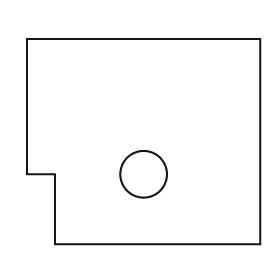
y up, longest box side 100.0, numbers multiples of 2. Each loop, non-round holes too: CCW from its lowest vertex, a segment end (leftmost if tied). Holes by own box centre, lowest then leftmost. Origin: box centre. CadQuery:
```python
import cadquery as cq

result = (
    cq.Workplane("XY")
    .moveTo(-38.0, -44.0)
    .lineTo(50.0, -44.0)
    .lineTo(50.0, 44.0)
    .lineTo(-50.0, 44.0)
    .lineTo(-50.0, -14.0)
    .lineTo(-38.0, -14.0)
    .close()
    .moveTo(0.0, -14.0)
    .circle(10.0)
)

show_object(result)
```